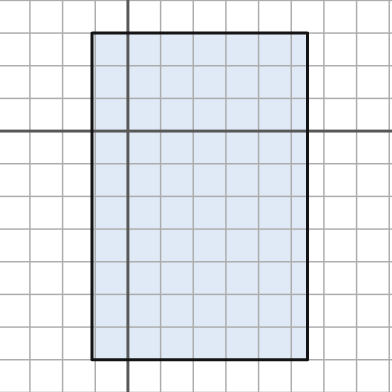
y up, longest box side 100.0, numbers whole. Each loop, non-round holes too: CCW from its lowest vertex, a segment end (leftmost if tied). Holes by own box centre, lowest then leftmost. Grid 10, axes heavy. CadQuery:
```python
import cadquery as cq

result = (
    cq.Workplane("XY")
    .moveTo(-11.0, -70.0)
    .lineTo(55.0, -70.0)
    .lineTo(55.0, 30.0)
    .lineTo(-11.0, 30.0)
    .close()
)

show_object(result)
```